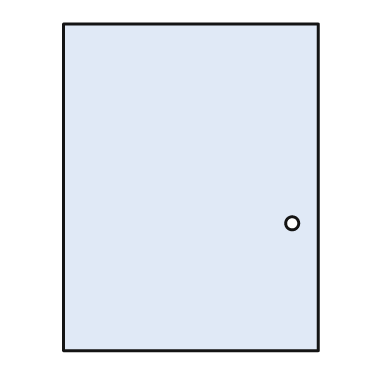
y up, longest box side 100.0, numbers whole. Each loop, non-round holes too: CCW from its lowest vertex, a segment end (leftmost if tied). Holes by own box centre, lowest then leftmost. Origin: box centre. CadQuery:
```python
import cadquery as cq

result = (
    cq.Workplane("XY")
    .moveTo(-39.0, -50.0)
    .lineTo(39.0, -50.0)
    .lineTo(39.0, 50.0)
    .lineTo(-39.0, 50.0)
    .close()
    .moveTo(31.0, -11.0)
    .circle(2.0)
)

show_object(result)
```